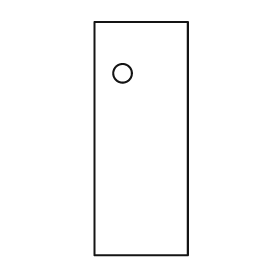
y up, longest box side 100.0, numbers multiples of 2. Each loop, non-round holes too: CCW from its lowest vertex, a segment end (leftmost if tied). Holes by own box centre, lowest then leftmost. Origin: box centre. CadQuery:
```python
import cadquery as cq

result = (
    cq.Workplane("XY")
    .moveTo(-20.0, -50.0)
    .lineTo(20.0, -50.0)
    .lineTo(20.0, 50.0)
    .lineTo(-20.0, 50.0)
    .close()
    .moveTo(-8.0, 28.0)
    .circle(4.0)
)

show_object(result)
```